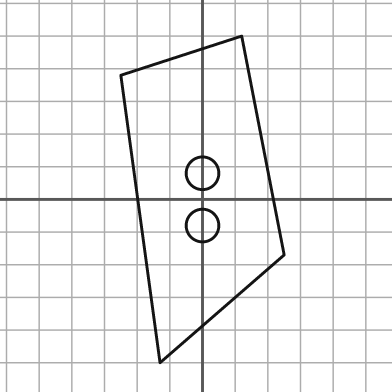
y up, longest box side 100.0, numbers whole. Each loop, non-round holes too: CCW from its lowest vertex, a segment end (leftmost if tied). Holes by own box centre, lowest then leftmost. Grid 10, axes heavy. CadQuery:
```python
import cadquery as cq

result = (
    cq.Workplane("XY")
    .moveTo(-13.0, -50.0)
    .lineTo(25.0, -17.0)
    .lineTo(12.0, 50.0)
    .lineTo(-25.0, 38.0)
    .close()
    .moveTo(0.0, -8.0)
    .circle(5.0)
    .moveTo(0.0, 8.0)
    .circle(5.0)
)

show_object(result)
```